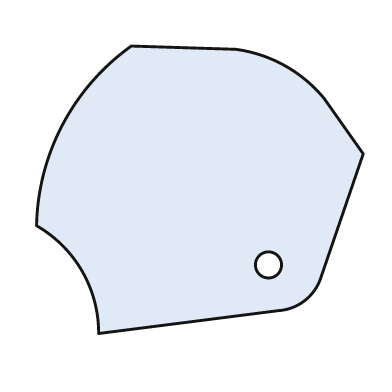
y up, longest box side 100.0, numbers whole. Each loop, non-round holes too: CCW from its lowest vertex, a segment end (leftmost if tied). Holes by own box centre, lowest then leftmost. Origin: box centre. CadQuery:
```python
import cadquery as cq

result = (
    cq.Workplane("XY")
    .moveTo(-31.0, -44.0)
    .lineTo(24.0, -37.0)
    .threePointArc((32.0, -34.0), (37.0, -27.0))
    .lineTo(50.0, 11.0)
    .lineTo(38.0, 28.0)
    .threePointArc((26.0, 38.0), (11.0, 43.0))
    .lineTo(-21.0, 44.0)
    .threePointArc((-42.0, 20.0), (-50.0, -11.0))
    .threePointArc((-36.0, -25.0), (-31.0, -44.0))
    .close()
    .moveTo(21.0, -23.0)
    .circle(4.0)
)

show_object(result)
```